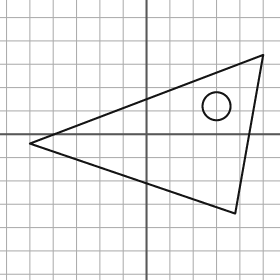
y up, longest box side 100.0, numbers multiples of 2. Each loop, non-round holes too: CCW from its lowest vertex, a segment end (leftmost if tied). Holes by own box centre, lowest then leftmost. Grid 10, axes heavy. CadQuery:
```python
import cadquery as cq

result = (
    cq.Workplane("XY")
    .moveTo(38.0, -34.0)
    .lineTo(50.0, 34.0)
    .lineTo(-50.0, -4.0)
    .close()
    .moveTo(30.0, 12.0)
    .circle(6.0)
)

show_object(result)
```